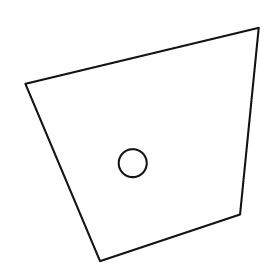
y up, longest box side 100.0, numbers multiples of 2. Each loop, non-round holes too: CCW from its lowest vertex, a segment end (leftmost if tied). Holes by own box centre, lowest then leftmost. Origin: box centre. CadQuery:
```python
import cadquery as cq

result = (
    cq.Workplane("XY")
    .moveTo(-18.0, -50.0)
    .lineTo(42.0, -30.0)
    .lineTo(50.0, 50.0)
    .lineTo(-50.0, 26.0)
    .close()
    .moveTo(-4.0, -8.0)
    .circle(6.0)
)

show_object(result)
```